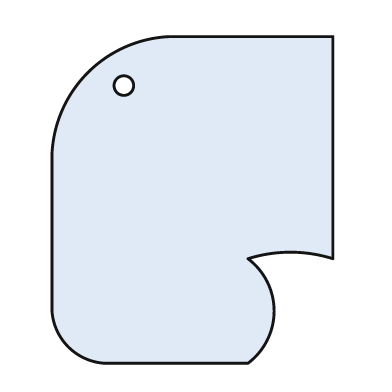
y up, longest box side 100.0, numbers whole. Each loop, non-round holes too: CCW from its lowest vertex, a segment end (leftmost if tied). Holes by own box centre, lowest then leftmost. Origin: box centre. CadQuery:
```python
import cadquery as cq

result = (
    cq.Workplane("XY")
    .moveTo(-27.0, -50.0)
    .lineTo(17.0, -50.0)
    .threePointArc((25.0, -34.0), (17.0, -18.0))
    .threePointArc((30.0, -16.0), (43.0, -18.0))
    .lineTo(43.0, 50.0)
    .lineTo(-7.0, 50.0)
    .threePointArc((-32.0, 39.0), (-43.0, 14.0))
    .lineTo(-43.0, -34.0)
    .threePointArc((-38.0, -45.0), (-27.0, -50.0))
    .close()
    .moveTo(-21.0, 35.0)
    .circle(3.0)
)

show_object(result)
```